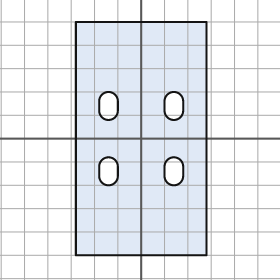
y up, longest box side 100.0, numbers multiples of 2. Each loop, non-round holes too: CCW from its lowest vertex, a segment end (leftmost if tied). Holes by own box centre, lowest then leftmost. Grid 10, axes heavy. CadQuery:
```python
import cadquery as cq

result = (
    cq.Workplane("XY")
    .moveTo(-28.0, -50.0)
    .lineTo(28.0, -50.0)
    .lineTo(28.0, 50.0)
    .lineTo(-28.0, 50.0)
    .close()
    .moveTo(-18.0, -16.0)
    .threePointArc((-14.0, -20.0), (-10.0, -16.0))
    .lineTo(-10.0, -12.0)
    .threePointArc((-14.0, -8.0), (-18.0, -12.0))
    .close()
    .moveTo(10.0, -16.0)
    .threePointArc((14.0, -20.0), (18.0, -16.0))
    .lineTo(18.0, -12.0)
    .threePointArc((14.0, -8.0), (10.0, -12.0))
    .close()
    .moveTo(-18.0, 12.0)
    .threePointArc((-14.0, 8.0), (-10.0, 12.0))
    .lineTo(-10.0, 16.0)
    .threePointArc((-14.0, 20.0), (-18.0, 16.0))
    .close()
    .moveTo(10.0, 12.0)
    .threePointArc((14.0, 8.0), (18.0, 12.0))
    .lineTo(18.0, 16.0)
    .threePointArc((14.0, 20.0), (10.0, 16.0))
    .close()
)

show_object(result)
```